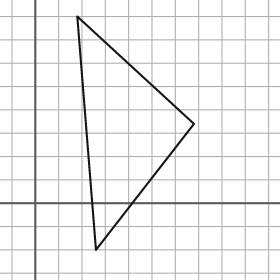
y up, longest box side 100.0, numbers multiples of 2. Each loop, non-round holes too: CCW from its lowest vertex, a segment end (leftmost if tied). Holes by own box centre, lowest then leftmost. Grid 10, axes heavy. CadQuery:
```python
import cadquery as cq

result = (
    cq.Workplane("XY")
    .moveTo(26.0, -20.0)
    .lineTo(68.0, 34.0)
    .lineTo(18.0, 80.0)
    .close()
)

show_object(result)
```